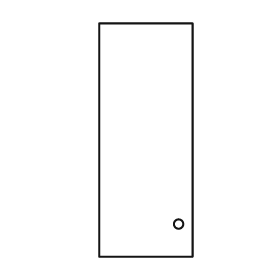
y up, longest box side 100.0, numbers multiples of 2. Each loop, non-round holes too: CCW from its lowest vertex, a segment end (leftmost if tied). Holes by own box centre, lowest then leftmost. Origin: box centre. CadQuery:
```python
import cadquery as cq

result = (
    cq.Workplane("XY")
    .moveTo(-20.0, -50.0)
    .lineTo(20.0, -50.0)
    .lineTo(20.0, 50.0)
    .lineTo(-20.0, 50.0)
    .close()
    .moveTo(14.0, -36.0)
    .circle(2.0)
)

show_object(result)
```